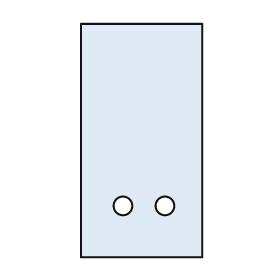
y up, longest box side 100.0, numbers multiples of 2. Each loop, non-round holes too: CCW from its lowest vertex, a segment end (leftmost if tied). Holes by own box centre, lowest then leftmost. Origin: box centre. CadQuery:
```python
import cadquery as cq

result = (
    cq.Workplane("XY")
    .moveTo(-26.0, -50.0)
    .lineTo(26.0, -50.0)
    .lineTo(26.0, 50.0)
    .lineTo(-26.0, 50.0)
    .close()
    .moveTo(-8.0, -28.0)
    .circle(4.0)
    .moveTo(10.0, -28.0)
    .circle(4.0)
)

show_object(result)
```